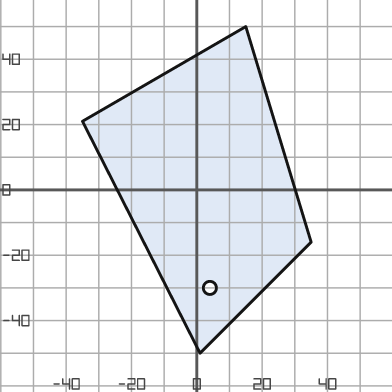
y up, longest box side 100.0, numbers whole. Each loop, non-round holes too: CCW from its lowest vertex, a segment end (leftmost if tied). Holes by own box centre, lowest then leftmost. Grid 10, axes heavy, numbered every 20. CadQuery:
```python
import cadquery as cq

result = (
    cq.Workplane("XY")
    .moveTo(1.0, -50.0)
    .lineTo(35.0, -16.0)
    .lineTo(15.0, 50.0)
    .lineTo(-35.0, 21.0)
    .close()
    .moveTo(4.0, -30.0)
    .circle(2.0)
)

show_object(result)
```